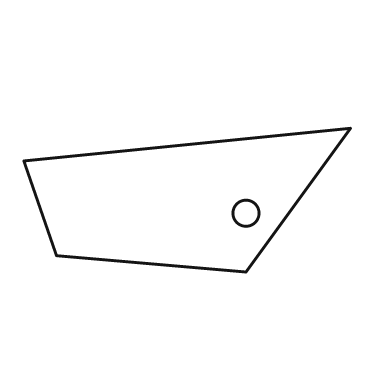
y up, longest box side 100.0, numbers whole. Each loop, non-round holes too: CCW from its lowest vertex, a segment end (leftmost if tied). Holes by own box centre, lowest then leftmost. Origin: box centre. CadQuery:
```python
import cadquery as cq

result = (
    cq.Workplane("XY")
    .moveTo(18.0, -22.0)
    .lineTo(50.0, 22.0)
    .lineTo(-50.0, 12.0)
    .lineTo(-40.0, -17.0)
    .close()
    .moveTo(18.0, -4.0)
    .circle(4.0)
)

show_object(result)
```